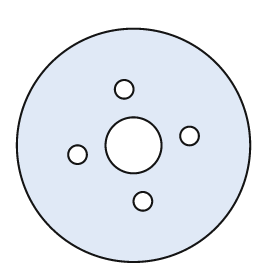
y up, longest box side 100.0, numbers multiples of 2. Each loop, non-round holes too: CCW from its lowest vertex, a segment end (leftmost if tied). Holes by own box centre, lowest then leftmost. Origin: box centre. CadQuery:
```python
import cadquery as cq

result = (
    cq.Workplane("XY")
    .moveTo(0.0, 0.0)
    .circle(50.0)
    .moveTo(4.0, -24.0)
    .circle(4.0)
    .moveTo(-24.0, -4.0)
    .circle(4.0)
    .moveTo(0.0, 0.0)
    .circle(12.0)
    .moveTo(24.0, 4.0)
    .circle(4.0)
    .moveTo(-4.0, 24.0)
    .circle(4.0)
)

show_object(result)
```